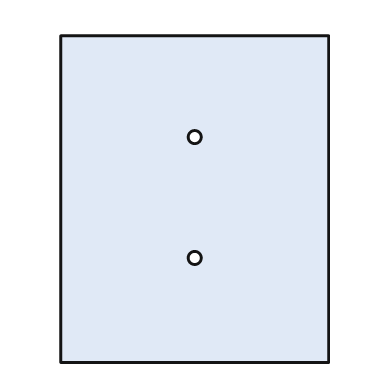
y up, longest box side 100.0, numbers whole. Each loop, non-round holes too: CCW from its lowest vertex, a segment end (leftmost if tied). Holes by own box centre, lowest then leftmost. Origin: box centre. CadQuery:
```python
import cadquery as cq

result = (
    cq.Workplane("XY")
    .moveTo(-41.0, -50.0)
    .lineTo(41.0, -50.0)
    .lineTo(41.0, 50.0)
    .lineTo(-41.0, 50.0)
    .close()
    .moveTo(0.0, -18.0)
    .circle(2.0)
    .moveTo(0.0, 19.0)
    .circle(2.0)
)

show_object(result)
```